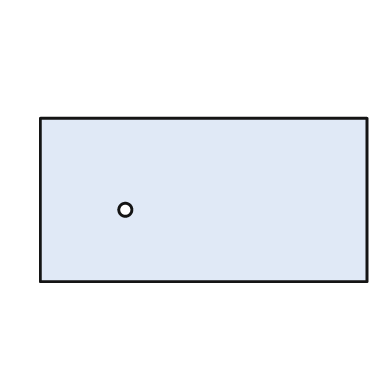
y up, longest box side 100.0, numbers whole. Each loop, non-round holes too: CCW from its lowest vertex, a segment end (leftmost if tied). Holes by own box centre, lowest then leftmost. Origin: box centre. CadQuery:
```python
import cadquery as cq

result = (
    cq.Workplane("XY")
    .moveTo(-50.0, -25.0)
    .lineTo(50.0, -25.0)
    .lineTo(50.0, 25.0)
    .lineTo(-50.0, 25.0)
    .close()
    .moveTo(-24.0, -3.0)
    .circle(2.0)
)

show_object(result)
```